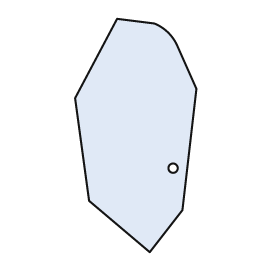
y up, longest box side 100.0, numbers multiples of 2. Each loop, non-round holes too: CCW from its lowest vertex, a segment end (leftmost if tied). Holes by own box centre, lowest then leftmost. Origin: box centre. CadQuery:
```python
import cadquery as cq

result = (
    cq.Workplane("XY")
    .moveTo(6.0, -50.0)
    .lineTo(20.0, -32.0)
    .lineTo(26.0, 20.0)
    .lineTo(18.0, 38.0)
    .threePointArc((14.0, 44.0), (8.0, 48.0))
    .lineTo(-8.0, 50.0)
    .lineTo(-26.0, 16.0)
    .lineTo(-20.0, -28.0)
    .close()
    .moveTo(16.0, -14.0)
    .circle(2.0)
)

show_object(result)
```